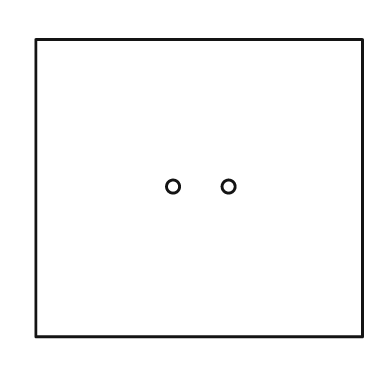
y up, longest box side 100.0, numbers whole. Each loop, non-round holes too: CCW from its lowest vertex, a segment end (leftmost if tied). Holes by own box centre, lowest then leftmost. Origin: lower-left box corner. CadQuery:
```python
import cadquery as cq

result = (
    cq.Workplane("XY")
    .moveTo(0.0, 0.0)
    .lineTo(100.0, 0.0)
    .lineTo(100.0, 91.0)
    .lineTo(0.0, 91.0)
    .close()
    .moveTo(42.0, 46.0)
    .circle(2.0)
    .moveTo(59.0, 46.0)
    .circle(2.0)
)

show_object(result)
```